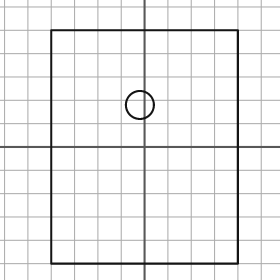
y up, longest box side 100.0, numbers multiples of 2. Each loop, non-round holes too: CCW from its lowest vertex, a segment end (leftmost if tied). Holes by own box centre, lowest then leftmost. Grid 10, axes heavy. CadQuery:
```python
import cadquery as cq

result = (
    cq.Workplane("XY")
    .moveTo(-40.0, -50.0)
    .lineTo(40.0, -50.0)
    .lineTo(40.0, 50.0)
    .lineTo(-40.0, 50.0)
    .close()
    .moveTo(-2.0, 18.0)
    .circle(6.0)
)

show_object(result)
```